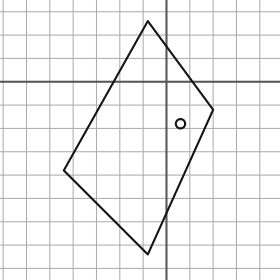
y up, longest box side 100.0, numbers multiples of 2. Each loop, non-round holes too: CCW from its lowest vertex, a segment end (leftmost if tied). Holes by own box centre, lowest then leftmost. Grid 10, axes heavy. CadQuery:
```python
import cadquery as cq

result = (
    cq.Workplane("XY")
    .moveTo(-8.0, -74.0)
    .lineTo(20.0, -12.0)
    .lineTo(-8.0, 26.0)
    .lineTo(-44.0, -38.0)
    .close()
    .moveTo(6.0, -18.0)
    .circle(2.0)
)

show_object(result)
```